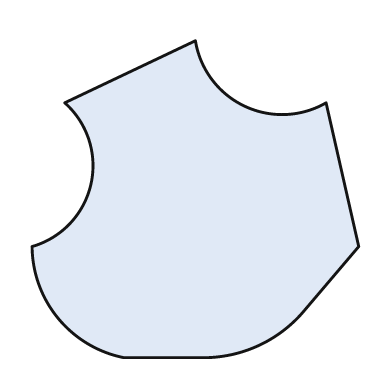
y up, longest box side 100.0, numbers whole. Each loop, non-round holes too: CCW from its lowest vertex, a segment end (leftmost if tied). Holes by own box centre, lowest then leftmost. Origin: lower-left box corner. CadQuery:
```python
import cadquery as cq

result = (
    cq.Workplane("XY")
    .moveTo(28.0, 0.0)
    .lineTo(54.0, 0.0)
    .threePointArc((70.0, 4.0), (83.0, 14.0))
    .lineTo(100.0, 34.0)
    .lineTo(90.0, 78.0)
    .threePointArc((65.0, 77.0), (50.0, 97.0))
    .lineTo(10.0, 78.0)
    .threePointArc((18.0, 53.0), (0.0, 34.0))
    .threePointArc((8.0, 12.0), (28.0, 0.0))
    .close()
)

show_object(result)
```